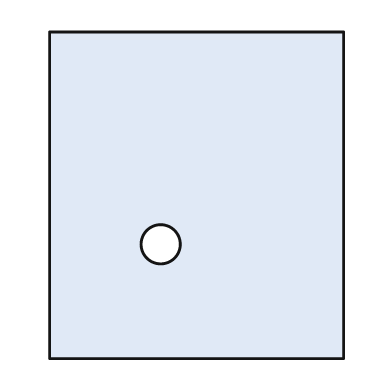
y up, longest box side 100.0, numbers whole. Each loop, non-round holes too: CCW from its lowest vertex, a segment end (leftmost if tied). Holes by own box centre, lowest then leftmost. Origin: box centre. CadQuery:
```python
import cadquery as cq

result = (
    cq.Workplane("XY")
    .moveTo(-45.0, -50.0)
    .lineTo(45.0, -50.0)
    .lineTo(45.0, 50.0)
    .lineTo(-45.0, 50.0)
    .close()
    .moveTo(-11.0, -15.0)
    .circle(6.0)
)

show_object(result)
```